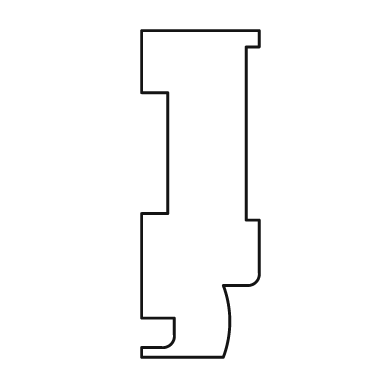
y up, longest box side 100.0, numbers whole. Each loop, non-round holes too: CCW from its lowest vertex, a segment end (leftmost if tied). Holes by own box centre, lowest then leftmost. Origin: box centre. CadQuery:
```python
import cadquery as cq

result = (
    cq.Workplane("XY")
    .moveTo(-18.0, -50.0)
    .lineTo(7.0, -50.0)
    .threePointArc((9.0, -39.0), (7.0, -28.0))
    .lineTo(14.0, -28.0)
    .threePointArc((17.0, -27.0), (18.0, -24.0))
    .lineTo(18.0, -8.0)
    .lineTo(14.0, -8.0)
    .lineTo(14.0, 45.0)
    .lineTo(18.0, 45.0)
    .lineTo(18.0, 50.0)
    .lineTo(-18.0, 50.0)
    .lineTo(-18.0, 31.0)
    .lineTo(-10.0, 31.0)
    .lineTo(-10.0, -6.0)
    .lineTo(-18.0, -6.0)
    .lineTo(-18.0, -38.0)
    .lineTo(-8.0, -38.0)
    .lineTo(-8.0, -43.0)
    .threePointArc((-9.0, -46.0), (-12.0, -47.0))
    .lineTo(-18.0, -47.0)
    .close()
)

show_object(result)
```